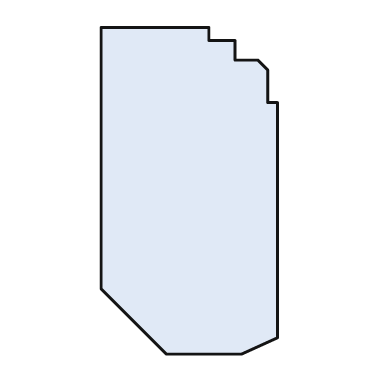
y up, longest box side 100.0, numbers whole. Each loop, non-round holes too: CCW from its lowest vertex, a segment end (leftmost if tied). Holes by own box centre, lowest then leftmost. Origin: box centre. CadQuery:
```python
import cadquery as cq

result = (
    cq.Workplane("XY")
    .moveTo(-7.0, -50.0)
    .lineTo(16.0, -50.0)
    .lineTo(27.0, -45.0)
    .lineTo(27.0, 27.0)
    .lineTo(24.0, 27.0)
    .lineTo(24.0, 37.0)
    .lineTo(21.0, 40.0)
    .lineTo(14.0, 40.0)
    .lineTo(14.0, 46.0)
    .lineTo(6.0, 46.0)
    .lineTo(6.0, 50.0)
    .lineTo(-27.0, 50.0)
    .lineTo(-27.0, -30.0)
    .close()
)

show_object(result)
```